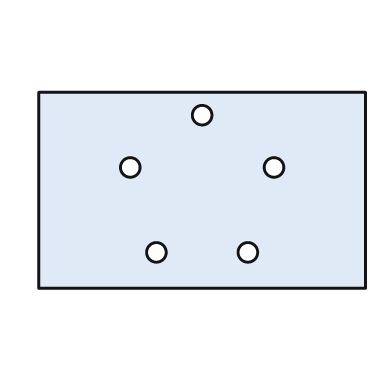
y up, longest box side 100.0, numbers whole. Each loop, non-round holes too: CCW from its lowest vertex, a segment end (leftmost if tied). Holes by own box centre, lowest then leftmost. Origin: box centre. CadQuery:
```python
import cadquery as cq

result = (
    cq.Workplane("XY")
    .moveTo(-50.0, -30.0)
    .lineTo(50.0, -30.0)
    .lineTo(50.0, 30.0)
    .lineTo(-50.0, 30.0)
    .close()
    .moveTo(-14.0, -19.0)
    .circle(3.0)
    .moveTo(14.0, -19.0)
    .circle(3.0)
    .moveTo(-22.0, 7.0)
    .circle(3.0)
    .moveTo(22.0, 7.0)
    .circle(3.0)
    .moveTo(0.0, 23.0)
    .circle(3.0)
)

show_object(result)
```